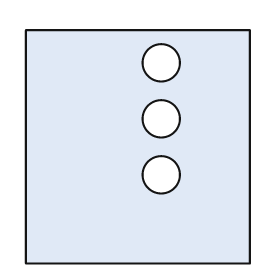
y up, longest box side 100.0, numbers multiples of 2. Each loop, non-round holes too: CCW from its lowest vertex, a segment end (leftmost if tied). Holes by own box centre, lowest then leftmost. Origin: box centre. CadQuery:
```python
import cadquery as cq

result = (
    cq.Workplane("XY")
    .moveTo(-48.0, -50.0)
    .lineTo(48.0, -50.0)
    .lineTo(48.0, 50.0)
    .lineTo(-48.0, 50.0)
    .close()
    .moveTo(10.0, -12.0)
    .circle(8.0)
    .moveTo(10.0, 12.0)
    .circle(8.0)
    .moveTo(10.0, 36.0)
    .circle(8.0)
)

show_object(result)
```